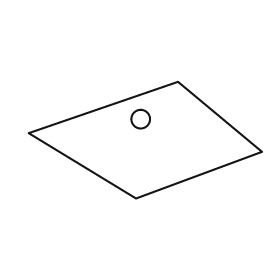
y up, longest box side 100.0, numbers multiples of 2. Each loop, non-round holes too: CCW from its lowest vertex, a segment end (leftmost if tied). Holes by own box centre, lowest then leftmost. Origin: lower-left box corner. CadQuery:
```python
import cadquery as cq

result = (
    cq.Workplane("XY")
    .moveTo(46.0, 0.0)
    .lineTo(100.0, 20.0)
    .lineTo(64.0, 50.0)
    .lineTo(0.0, 28.0)
    .close()
    .moveTo(48.0, 34.0)
    .circle(4.0)
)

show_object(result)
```